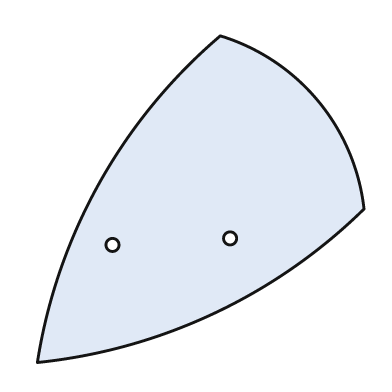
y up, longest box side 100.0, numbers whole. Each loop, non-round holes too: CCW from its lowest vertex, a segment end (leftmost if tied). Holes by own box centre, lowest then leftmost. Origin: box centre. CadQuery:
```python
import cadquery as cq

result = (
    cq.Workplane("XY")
    .moveTo(-50.0, -50.0)
    .threePointArc((4.0, -35.0), (50.0, -3.0))
    .threePointArc((36.0, 30.0), (6.0, 50.0))
    .threePointArc((-31.0, 5.0), (-50.0, -50.0))
    .close()
    .moveTo(-27.0, -14.0)
    .circle(2.0)
    .moveTo(9.0, -12.0)
    .circle(2.0)
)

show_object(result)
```